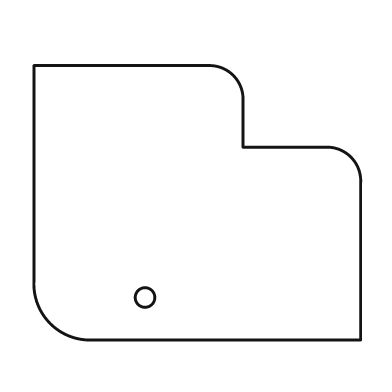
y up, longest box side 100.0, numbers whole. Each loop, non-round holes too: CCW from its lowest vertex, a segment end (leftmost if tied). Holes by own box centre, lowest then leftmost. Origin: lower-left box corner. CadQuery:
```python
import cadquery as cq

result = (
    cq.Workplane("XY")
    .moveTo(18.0, 0.0)
    .lineTo(100.0, 0.0)
    .lineTo(100.0, 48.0)
    .threePointArc((97.0, 56.0), (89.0, 59.0))
    .lineTo(64.0, 59.0)
    .lineTo(64.0, 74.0)
    .threePointArc((61.0, 81.0), (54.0, 84.0))
    .lineTo(0.0, 84.0)
    .lineTo(0.0, 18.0)
    .threePointArc((5.0, 5.0), (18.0, 0.0))
    .close()
    .moveTo(34.0, 13.0)
    .circle(3.0)
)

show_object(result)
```